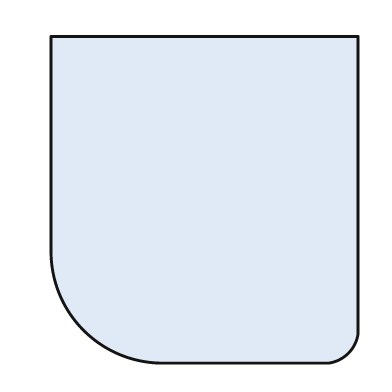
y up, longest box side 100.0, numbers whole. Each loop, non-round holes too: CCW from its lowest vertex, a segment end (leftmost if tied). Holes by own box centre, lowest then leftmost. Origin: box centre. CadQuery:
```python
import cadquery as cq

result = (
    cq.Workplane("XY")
    .moveTo(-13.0, -50.0)
    .lineTo(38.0, -50.0)
    .threePointArc((44.0, -47.0), (47.0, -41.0))
    .lineTo(47.0, 50.0)
    .lineTo(-47.0, 50.0)
    .lineTo(-47.0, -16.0)
    .threePointArc((-37.0, -40.0), (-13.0, -50.0))
    .close()
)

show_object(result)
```